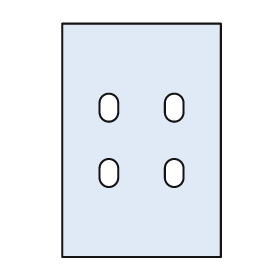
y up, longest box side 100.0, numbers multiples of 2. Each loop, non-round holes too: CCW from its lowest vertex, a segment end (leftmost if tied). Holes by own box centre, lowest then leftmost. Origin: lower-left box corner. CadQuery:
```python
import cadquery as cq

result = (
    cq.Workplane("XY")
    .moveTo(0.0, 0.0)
    .lineTo(68.0, 0.0)
    .lineTo(68.0, 100.0)
    .lineTo(0.0, 100.0)
    .close()
    .moveTo(16.0, 34.0)
    .threePointArc((20.0, 30.0), (24.0, 34.0))
    .lineTo(24.0, 38.0)
    .threePointArc((20.0, 42.0), (16.0, 38.0))
    .close()
    .moveTo(44.0, 34.0)
    .threePointArc((48.0, 30.0), (52.0, 34.0))
    .lineTo(52.0, 38.0)
    .threePointArc((48.0, 42.0), (44.0, 38.0))
    .close()
    .moveTo(16.0, 62.0)
    .threePointArc((20.0, 58.0), (24.0, 62.0))
    .lineTo(24.0, 66.0)
    .threePointArc((20.0, 70.0), (16.0, 66.0))
    .close()
    .moveTo(44.0, 62.0)
    .threePointArc((48.0, 58.0), (52.0, 62.0))
    .lineTo(52.0, 66.0)
    .threePointArc((48.0, 70.0), (44.0, 66.0))
    .close()
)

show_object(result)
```